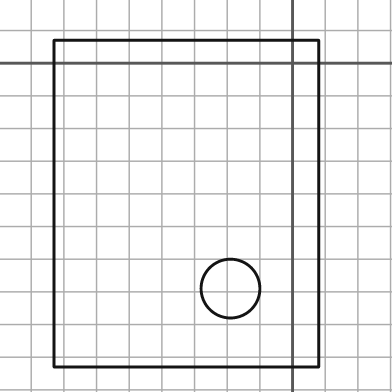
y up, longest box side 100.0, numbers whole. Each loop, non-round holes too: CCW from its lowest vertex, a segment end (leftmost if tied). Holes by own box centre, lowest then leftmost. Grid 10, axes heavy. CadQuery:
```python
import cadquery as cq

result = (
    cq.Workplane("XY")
    .moveTo(-73.0, -93.0)
    .lineTo(8.0, -93.0)
    .lineTo(8.0, 7.0)
    .lineTo(-73.0, 7.0)
    .close()
    .moveTo(-19.0, -69.0)
    .circle(9.0)
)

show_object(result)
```